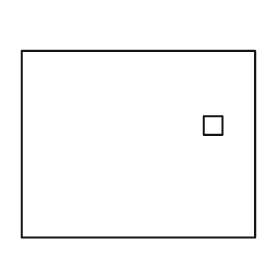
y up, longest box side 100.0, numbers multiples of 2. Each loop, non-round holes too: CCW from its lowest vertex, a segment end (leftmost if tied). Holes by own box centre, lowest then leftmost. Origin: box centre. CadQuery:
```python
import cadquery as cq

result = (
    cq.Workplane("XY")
    .moveTo(-50.0, -40.0)
    .lineTo(50.0, -40.0)
    .lineTo(50.0, 40.0)
    .lineTo(-50.0, 40.0)
    .close()
    .moveTo(28.0, 4.0)
    .lineTo(36.0, 4.0)
    .lineTo(36.0, 12.0)
    .lineTo(28.0, 12.0)
    .close()
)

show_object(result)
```